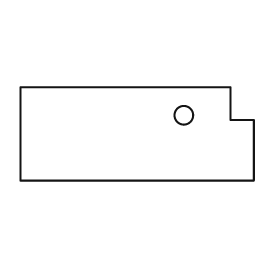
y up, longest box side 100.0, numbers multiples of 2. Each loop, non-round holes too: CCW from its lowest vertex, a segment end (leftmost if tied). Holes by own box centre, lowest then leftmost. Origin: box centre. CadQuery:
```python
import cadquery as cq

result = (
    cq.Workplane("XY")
    .moveTo(-50.0, -20.0)
    .lineTo(50.0, -20.0)
    .lineTo(50.0, 6.0)
    .lineTo(40.0, 6.0)
    .lineTo(40.0, 20.0)
    .lineTo(-50.0, 20.0)
    .close()
    .moveTo(20.0, 8.0)
    .circle(4.0)
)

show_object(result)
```